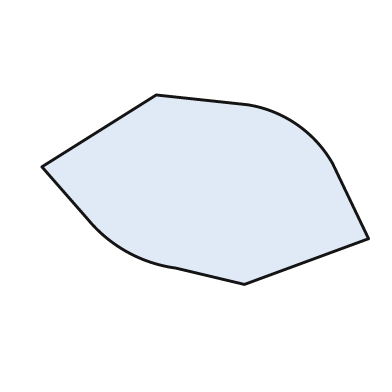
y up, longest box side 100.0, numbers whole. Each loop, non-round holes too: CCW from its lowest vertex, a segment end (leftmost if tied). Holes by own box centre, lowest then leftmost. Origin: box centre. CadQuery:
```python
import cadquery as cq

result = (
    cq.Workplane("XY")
    .moveTo(12.0, -29.0)
    .lineTo(50.0, -15.0)
    .lineTo(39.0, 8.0)
    .threePointArc((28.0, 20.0), (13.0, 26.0))
    .lineTo(-15.0, 29.0)
    .lineTo(-50.0, 7.0)
    .lineTo(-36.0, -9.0)
    .threePointArc((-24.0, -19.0), (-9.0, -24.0))
    .close()
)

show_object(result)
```